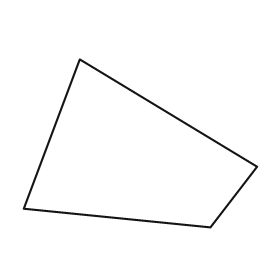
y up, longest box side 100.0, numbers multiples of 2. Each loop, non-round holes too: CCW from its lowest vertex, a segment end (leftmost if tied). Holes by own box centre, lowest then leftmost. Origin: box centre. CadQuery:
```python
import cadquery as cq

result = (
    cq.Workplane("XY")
    .moveTo(30.0, -36.0)
    .lineTo(50.0, -10.0)
    .lineTo(-26.0, 36.0)
    .lineTo(-50.0, -28.0)
    .close()
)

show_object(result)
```